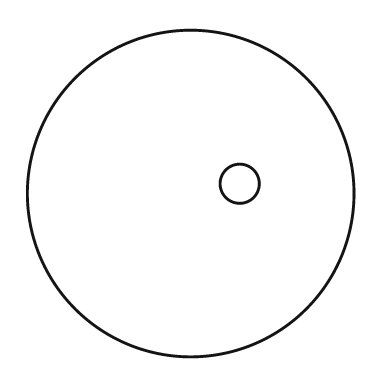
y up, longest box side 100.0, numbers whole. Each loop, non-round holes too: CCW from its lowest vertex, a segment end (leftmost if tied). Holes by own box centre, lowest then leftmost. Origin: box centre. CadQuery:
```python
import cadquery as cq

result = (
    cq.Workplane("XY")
    .moveTo(0.0, 0.0)
    .circle(50.0)
    .moveTo(15.0, 3.0)
    .circle(6.0)
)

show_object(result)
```